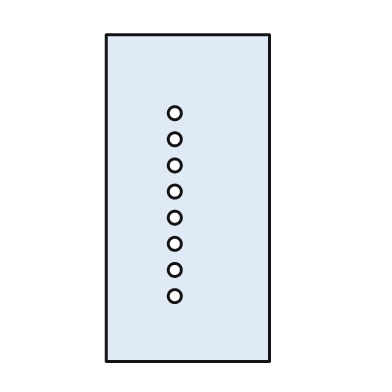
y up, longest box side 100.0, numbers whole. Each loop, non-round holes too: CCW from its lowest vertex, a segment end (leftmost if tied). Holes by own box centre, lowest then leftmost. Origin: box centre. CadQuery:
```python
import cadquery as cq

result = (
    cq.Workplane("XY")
    .moveTo(-25.0, -50.0)
    .lineTo(25.0, -50.0)
    .lineTo(25.0, 50.0)
    .lineTo(-25.0, 50.0)
    .close()
    .moveTo(-4.0, -30.0)
    .circle(2.0)
    .moveTo(-4.0, -22.0)
    .circle(2.0)
    .moveTo(-4.0, -14.0)
    .circle(2.0)
    .moveTo(-4.0, -6.0)
    .circle(2.0)
    .moveTo(-4.0, 2.0)
    .circle(2.0)
    .moveTo(-4.0, 10.0)
    .circle(2.0)
    .moveTo(-4.0, 18.0)
    .circle(2.0)
    .moveTo(-4.0, 26.0)
    .circle(2.0)
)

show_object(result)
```